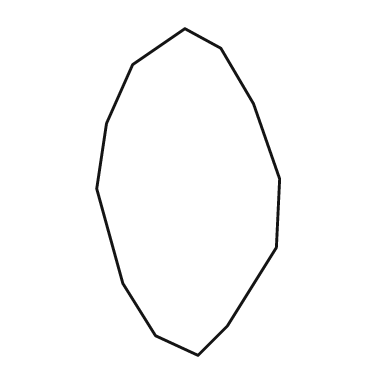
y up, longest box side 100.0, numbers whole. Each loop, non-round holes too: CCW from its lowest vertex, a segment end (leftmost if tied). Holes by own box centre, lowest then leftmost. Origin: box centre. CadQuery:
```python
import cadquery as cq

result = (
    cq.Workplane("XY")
    .moveTo(3.0, -50.0)
    .lineTo(12.0, -41.0)
    .lineTo(27.0, -17.0)
    .lineTo(28.0, 4.0)
    .lineTo(20.0, 27.0)
    .lineTo(10.0, 44.0)
    .lineTo(-1.0, 50.0)
    .lineTo(-17.0, 39.0)
    .lineTo(-25.0, 21.0)
    .lineTo(-28.0, 1.0)
    .lineTo(-20.0, -28.0)
    .lineTo(-10.0, -44.0)
    .close()
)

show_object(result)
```